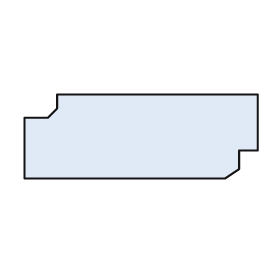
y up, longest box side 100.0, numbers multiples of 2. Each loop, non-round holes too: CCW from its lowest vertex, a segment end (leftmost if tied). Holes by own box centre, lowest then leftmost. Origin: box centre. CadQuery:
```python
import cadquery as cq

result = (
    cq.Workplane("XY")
    .moveTo(-50.0, -18.0)
    .lineTo(36.0, -18.0)
    .lineTo(42.0, -14.0)
    .lineTo(42.0, -6.0)
    .lineTo(50.0, -6.0)
    .lineTo(50.0, 18.0)
    .lineTo(-36.0, 18.0)
    .lineTo(-36.0, 12.0)
    .lineTo(-40.0, 8.0)
    .lineTo(-50.0, 8.0)
    .close()
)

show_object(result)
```